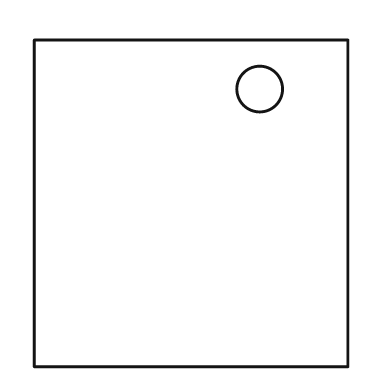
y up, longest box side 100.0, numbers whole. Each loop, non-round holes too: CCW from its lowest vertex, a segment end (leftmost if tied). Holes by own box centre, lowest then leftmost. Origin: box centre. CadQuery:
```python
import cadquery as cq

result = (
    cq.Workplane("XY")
    .moveTo(-48.0, -50.0)
    .lineTo(48.0, -50.0)
    .lineTo(48.0, 50.0)
    .lineTo(-48.0, 50.0)
    .close()
    .moveTo(21.0, 35.0)
    .circle(7.0)
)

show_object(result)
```